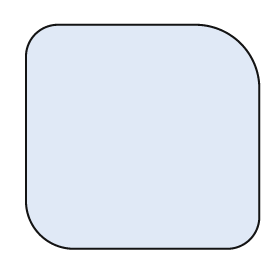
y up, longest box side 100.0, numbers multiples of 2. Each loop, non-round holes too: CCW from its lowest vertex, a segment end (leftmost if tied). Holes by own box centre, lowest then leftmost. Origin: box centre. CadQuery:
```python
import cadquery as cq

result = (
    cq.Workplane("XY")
    .moveTo(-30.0, -48.0)
    .lineTo(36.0, -48.0)
    .threePointArc((46.0, -44.0), (50.0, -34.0))
    .lineTo(50.0, 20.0)
    .threePointArc((42.0, 40.0), (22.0, 48.0))
    .lineTo(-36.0, 48.0)
    .threePointArc((-46.0, 44.0), (-50.0, 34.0))
    .lineTo(-50.0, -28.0)
    .threePointArc((-44.0, -42.0), (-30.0, -48.0))
    .close()
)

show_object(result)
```